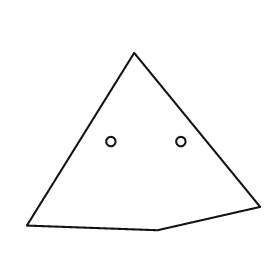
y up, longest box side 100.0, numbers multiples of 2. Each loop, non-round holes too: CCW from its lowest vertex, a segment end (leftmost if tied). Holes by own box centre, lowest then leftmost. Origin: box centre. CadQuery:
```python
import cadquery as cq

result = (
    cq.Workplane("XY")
    .moveTo(6.0, -38.0)
    .lineTo(50.0, -28.0)
    .lineTo(-4.0, 38.0)
    .lineTo(-50.0, -36.0)
    .close()
    .moveTo(-14.0, 0.0)
    .circle(2.0)
    .moveTo(16.0, 0.0)
    .circle(2.0)
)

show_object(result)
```